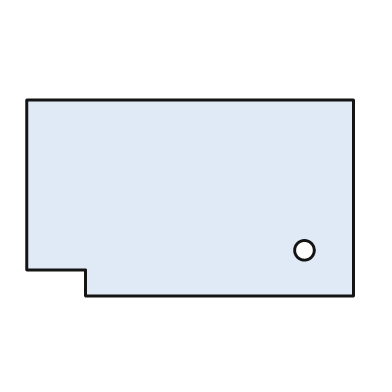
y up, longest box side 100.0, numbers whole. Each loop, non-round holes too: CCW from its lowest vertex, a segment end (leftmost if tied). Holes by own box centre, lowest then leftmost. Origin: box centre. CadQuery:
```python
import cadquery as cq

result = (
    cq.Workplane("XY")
    .moveTo(-32.0, -30.0)
    .lineTo(50.0, -30.0)
    .lineTo(50.0, 30.0)
    .lineTo(-50.0, 30.0)
    .lineTo(-50.0, -22.0)
    .lineTo(-32.0, -22.0)
    .close()
    .moveTo(35.0, -16.0)
    .circle(3.0)
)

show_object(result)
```